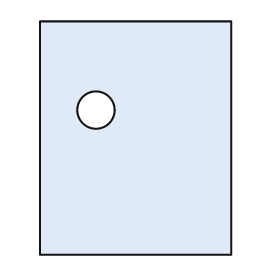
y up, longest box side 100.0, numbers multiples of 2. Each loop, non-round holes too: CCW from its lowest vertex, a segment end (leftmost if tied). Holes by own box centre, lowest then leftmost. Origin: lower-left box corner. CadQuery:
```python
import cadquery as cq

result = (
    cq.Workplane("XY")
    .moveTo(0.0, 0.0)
    .lineTo(82.0, 0.0)
    .lineTo(82.0, 100.0)
    .lineTo(0.0, 100.0)
    .close()
    .moveTo(24.0, 62.0)
    .circle(8.0)
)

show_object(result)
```